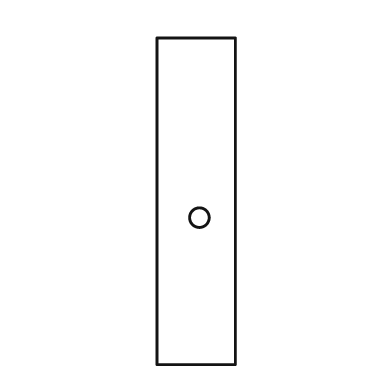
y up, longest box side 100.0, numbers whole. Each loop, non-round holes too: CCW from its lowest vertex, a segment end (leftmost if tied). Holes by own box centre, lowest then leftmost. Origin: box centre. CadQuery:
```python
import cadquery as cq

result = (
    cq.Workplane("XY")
    .moveTo(-12.0, -50.0)
    .lineTo(12.0, -50.0)
    .lineTo(12.0, 50.0)
    .lineTo(-12.0, 50.0)
    .close()
    .moveTo(1.0, -5.0)
    .circle(3.0)
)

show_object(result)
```